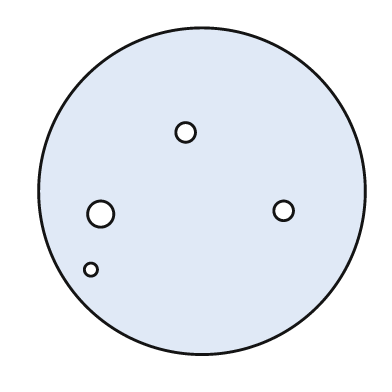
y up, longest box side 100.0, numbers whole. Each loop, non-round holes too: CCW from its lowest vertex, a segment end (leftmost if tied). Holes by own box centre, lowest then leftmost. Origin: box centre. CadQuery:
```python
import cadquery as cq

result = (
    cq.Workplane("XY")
    .moveTo(0.0, 0.0)
    .circle(50.0)
    .moveTo(-34.0, -24.0)
    .circle(2.0)
    .moveTo(-31.0, -7.0)
    .circle(4.0)
    .moveTo(25.0, -6.0)
    .circle(3.0)
    .moveTo(-5.0, 18.0)
    .circle(3.0)
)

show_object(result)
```